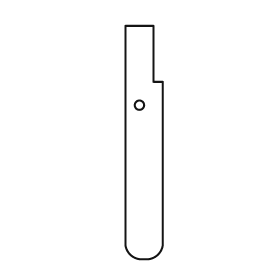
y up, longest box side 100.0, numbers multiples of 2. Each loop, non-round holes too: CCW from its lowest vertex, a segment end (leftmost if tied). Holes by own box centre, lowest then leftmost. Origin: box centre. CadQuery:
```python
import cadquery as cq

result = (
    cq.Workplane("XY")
    .moveTo(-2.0, -50.0)
    .lineTo(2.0, -50.0)
    .threePointArc((6.0, -48.0), (8.0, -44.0))
    .lineTo(8.0, 26.0)
    .lineTo(4.0, 26.0)
    .lineTo(4.0, 50.0)
    .lineTo(-8.0, 50.0)
    .lineTo(-8.0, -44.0)
    .threePointArc((-6.0, -48.0), (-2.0, -50.0))
    .close()
    .moveTo(-2.0, 16.0)
    .circle(2.0)
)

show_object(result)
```